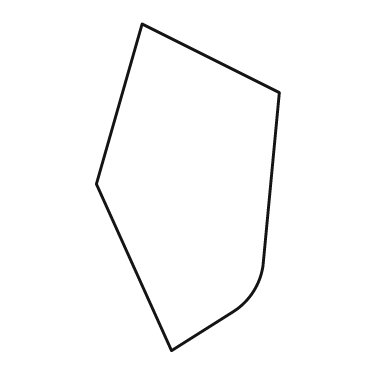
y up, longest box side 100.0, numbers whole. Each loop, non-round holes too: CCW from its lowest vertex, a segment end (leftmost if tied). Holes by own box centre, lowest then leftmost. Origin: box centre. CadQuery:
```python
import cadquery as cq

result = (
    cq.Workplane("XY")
    .moveTo(-5.0, -50.0)
    .lineTo(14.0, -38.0)
    .threePointArc((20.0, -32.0), (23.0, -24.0))
    .lineTo(28.0, 29.0)
    .lineTo(-14.0, 50.0)
    .lineTo(-28.0, 1.0)
    .close()
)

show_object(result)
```